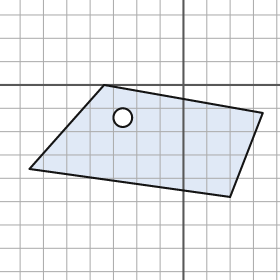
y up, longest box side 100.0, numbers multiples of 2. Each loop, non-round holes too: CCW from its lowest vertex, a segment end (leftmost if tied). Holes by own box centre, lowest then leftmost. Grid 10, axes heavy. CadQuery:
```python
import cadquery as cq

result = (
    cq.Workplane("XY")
    .moveTo(20.0, -48.0)
    .lineTo(34.0, -12.0)
    .lineTo(-34.0, 0.0)
    .lineTo(-66.0, -36.0)
    .close()
    .moveTo(-26.0, -14.0)
    .circle(4.0)
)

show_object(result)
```